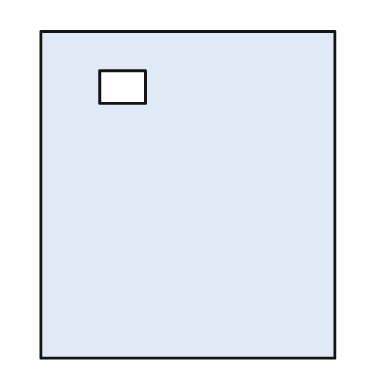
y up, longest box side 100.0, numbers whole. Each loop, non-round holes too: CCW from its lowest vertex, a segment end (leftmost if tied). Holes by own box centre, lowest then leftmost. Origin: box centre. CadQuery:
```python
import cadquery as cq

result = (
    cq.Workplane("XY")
    .moveTo(-45.0, -50.0)
    .lineTo(45.0, -50.0)
    .lineTo(45.0, 50.0)
    .lineTo(-45.0, 50.0)
    .close()
    .moveTo(-27.0, 28.0)
    .lineTo(-13.0, 28.0)
    .lineTo(-13.0, 38.0)
    .lineTo(-27.0, 38.0)
    .close()
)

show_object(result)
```